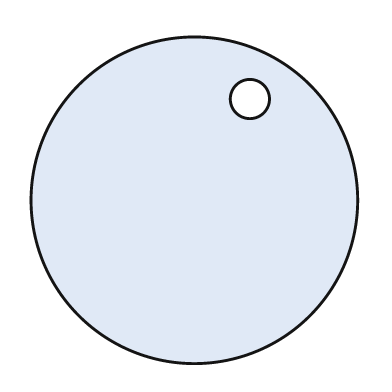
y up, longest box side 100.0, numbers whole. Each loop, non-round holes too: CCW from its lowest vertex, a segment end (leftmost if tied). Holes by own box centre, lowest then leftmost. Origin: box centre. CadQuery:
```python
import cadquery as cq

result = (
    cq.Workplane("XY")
    .moveTo(0.0, 0.0)
    .circle(50.0)
    .moveTo(17.0, 31.0)
    .circle(6.0)
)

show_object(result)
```